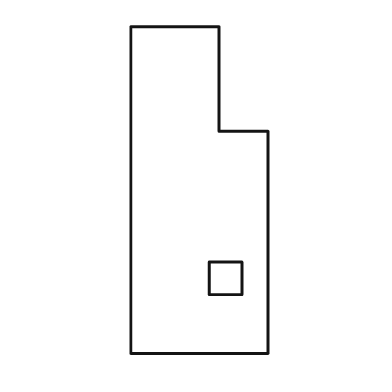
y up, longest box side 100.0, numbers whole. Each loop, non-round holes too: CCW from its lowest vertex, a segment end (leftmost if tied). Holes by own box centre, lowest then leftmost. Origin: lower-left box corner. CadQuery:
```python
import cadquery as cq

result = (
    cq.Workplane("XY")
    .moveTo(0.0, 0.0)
    .lineTo(42.0, 0.0)
    .lineTo(42.0, 68.0)
    .lineTo(27.0, 68.0)
    .lineTo(27.0, 100.0)
    .lineTo(0.0, 100.0)
    .close()
    .moveTo(24.0, 18.0)
    .lineTo(34.0, 18.0)
    .lineTo(34.0, 28.0)
    .lineTo(24.0, 28.0)
    .close()
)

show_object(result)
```